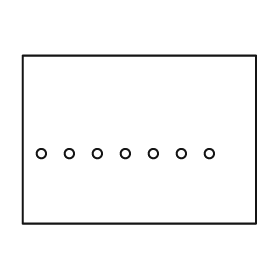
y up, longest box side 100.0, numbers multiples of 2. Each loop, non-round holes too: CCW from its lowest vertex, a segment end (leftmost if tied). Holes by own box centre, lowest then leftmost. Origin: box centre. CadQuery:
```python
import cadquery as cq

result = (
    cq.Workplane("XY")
    .moveTo(-50.0, -36.0)
    .lineTo(50.0, -36.0)
    .lineTo(50.0, 36.0)
    .lineTo(-50.0, 36.0)
    .close()
    .moveTo(-42.0, -6.0)
    .circle(2.0)
    .moveTo(-30.0, -6.0)
    .circle(2.0)
    .moveTo(-18.0, -6.0)
    .circle(2.0)
    .moveTo(-6.0, -6.0)
    .circle(2.0)
    .moveTo(6.0, -6.0)
    .circle(2.0)
    .moveTo(18.0, -6.0)
    .circle(2.0)
    .moveTo(30.0, -6.0)
    .circle(2.0)
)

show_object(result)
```